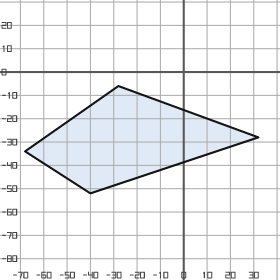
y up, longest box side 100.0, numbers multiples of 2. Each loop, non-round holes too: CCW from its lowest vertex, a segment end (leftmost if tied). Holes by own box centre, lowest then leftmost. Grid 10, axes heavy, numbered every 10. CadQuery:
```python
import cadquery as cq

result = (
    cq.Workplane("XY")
    .moveTo(-40.0, -52.0)
    .lineTo(32.0, -28.0)
    .lineTo(-28.0, -6.0)
    .lineTo(-68.0, -34.0)
    .close()
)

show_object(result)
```